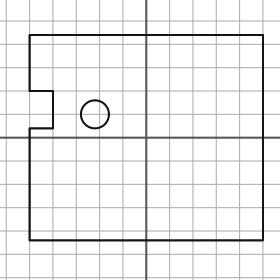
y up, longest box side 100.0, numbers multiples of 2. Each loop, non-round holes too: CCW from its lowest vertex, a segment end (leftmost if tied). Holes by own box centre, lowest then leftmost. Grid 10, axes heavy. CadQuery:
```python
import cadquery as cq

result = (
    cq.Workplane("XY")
    .moveTo(-50.0, -44.0)
    .lineTo(50.0, -44.0)
    .lineTo(50.0, 44.0)
    .lineTo(-50.0, 44.0)
    .lineTo(-50.0, 20.0)
    .lineTo(-40.0, 20.0)
    .lineTo(-40.0, 4.0)
    .lineTo(-50.0, 4.0)
    .close()
    .moveTo(-22.0, 10.0)
    .circle(6.0)
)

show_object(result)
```